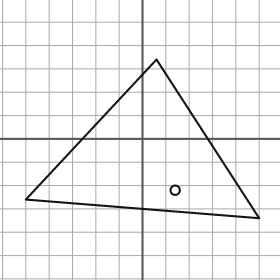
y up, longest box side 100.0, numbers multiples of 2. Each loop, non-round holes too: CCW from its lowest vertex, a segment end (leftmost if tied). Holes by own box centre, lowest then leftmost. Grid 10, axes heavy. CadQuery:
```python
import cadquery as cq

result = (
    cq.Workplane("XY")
    .moveTo(50.0, -34.0)
    .lineTo(6.0, 34.0)
    .lineTo(-50.0, -26.0)
    .close()
    .moveTo(14.0, -22.0)
    .circle(2.0)
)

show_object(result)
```